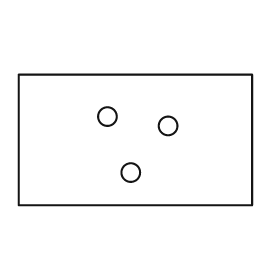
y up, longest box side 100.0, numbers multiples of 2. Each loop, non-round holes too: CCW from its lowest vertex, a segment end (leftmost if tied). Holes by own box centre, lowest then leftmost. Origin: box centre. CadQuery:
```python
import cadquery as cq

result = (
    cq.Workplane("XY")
    .moveTo(-50.0, -28.0)
    .lineTo(50.0, -28.0)
    .lineTo(50.0, 28.0)
    .lineTo(-50.0, 28.0)
    .close()
    .moveTo(-2.0, -14.0)
    .circle(4.0)
    .moveTo(14.0, 6.0)
    .circle(4.0)
    .moveTo(-12.0, 10.0)
    .circle(4.0)
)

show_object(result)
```